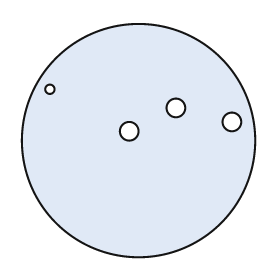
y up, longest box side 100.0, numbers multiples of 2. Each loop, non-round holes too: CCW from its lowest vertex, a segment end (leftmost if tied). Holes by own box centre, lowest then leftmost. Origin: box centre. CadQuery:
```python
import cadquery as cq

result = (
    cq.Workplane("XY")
    .moveTo(0.0, 0.0)
    .circle(50.0)
    .moveTo(-4.0, 4.0)
    .circle(4.0)
    .moveTo(40.0, 8.0)
    .circle(4.0)
    .moveTo(16.0, 14.0)
    .circle(4.0)
    .moveTo(-38.0, 22.0)
    .circle(2.0)
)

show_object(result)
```